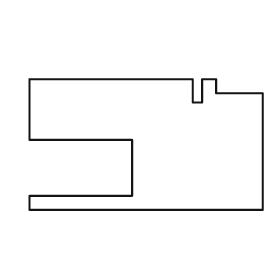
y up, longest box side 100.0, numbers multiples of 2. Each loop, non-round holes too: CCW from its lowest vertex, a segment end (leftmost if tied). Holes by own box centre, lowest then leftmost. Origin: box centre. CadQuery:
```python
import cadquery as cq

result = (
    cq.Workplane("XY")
    .moveTo(-50.0, -28.0)
    .lineTo(50.0, -28.0)
    .lineTo(50.0, 22.0)
    .lineTo(30.0, 22.0)
    .lineTo(30.0, 28.0)
    .lineTo(24.0, 28.0)
    .lineTo(24.0, 18.0)
    .lineTo(20.0, 18.0)
    .lineTo(20.0, 28.0)
    .lineTo(-50.0, 28.0)
    .lineTo(-50.0, 2.0)
    .lineTo(-6.0, 2.0)
    .lineTo(-6.0, -22.0)
    .lineTo(-50.0, -22.0)
    .close()
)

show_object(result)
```